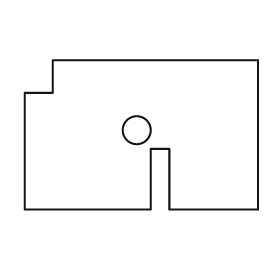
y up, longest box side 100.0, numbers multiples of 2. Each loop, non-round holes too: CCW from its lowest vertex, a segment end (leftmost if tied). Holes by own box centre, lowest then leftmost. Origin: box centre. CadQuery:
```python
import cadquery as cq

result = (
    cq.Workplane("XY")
    .moveTo(-50.0, -32.0)
    .lineTo(4.0, -32.0)
    .lineTo(4.0, -6.0)
    .lineTo(12.0, -6.0)
    .lineTo(12.0, -32.0)
    .lineTo(50.0, -32.0)
    .lineTo(50.0, 32.0)
    .lineTo(-38.0, 32.0)
    .lineTo(-38.0, 18.0)
    .lineTo(-50.0, 18.0)
    .close()
    .moveTo(-2.0, 2.0)
    .circle(6.0)
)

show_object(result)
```